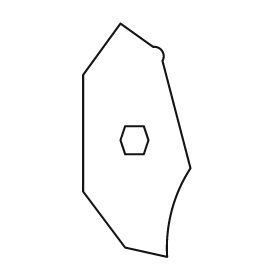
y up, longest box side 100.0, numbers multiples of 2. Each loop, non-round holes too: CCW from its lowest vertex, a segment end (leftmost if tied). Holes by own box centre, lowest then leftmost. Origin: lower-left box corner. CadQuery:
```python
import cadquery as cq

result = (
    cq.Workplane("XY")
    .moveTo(36.0, 0.0)
    .threePointArc((38.0, 20.0), (46.0, 38.0))
    .lineTo(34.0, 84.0)
    .threePointArc((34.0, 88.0), (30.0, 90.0))
    .lineTo(16.0, 100.0)
    .lineTo(0.0, 78.0)
    .lineTo(0.0, 28.0)
    .lineTo(18.0, 4.0)
    .close()
    .moveTo(18.0, 44.0)
    .lineTo(26.0, 44.0)
    .lineTo(28.0, 50.0)
    .lineTo(26.0, 56.0)
    .lineTo(18.0, 56.0)
    .lineTo(16.0, 50.0)
    .close()
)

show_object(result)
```